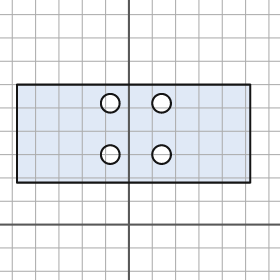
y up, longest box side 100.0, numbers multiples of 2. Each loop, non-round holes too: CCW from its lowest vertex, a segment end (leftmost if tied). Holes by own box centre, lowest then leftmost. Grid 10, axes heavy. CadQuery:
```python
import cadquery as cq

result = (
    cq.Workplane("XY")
    .moveTo(-48.0, 18.0)
    .lineTo(52.0, 18.0)
    .lineTo(52.0, 60.0)
    .lineTo(-48.0, 60.0)
    .close()
    .moveTo(-8.0, 30.0)
    .circle(4.0)
    .moveTo(14.0, 30.0)
    .circle(4.0)
    .moveTo(-8.0, 52.0)
    .circle(4.0)
    .moveTo(14.0, 52.0)
    .circle(4.0)
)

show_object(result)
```